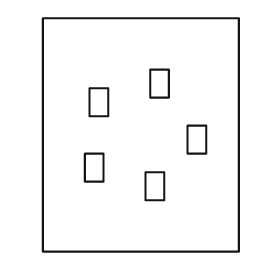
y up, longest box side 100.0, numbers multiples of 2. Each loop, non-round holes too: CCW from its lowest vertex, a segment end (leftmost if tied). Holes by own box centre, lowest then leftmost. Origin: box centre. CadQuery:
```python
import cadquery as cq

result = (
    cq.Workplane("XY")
    .moveTo(-42.0, -50.0)
    .lineTo(42.0, -50.0)
    .lineTo(42.0, 50.0)
    .lineTo(-42.0, 50.0)
    .close()
    .moveTo(2.0, -28.0)
    .lineTo(10.0, -28.0)
    .lineTo(10.0, -16.0)
    .lineTo(2.0, -16.0)
    .close()
    .moveTo(-24.0, -20.0)
    .lineTo(-16.0, -20.0)
    .lineTo(-16.0, -8.0)
    .lineTo(-24.0, -8.0)
    .close()
    .moveTo(20.0, -8.0)
    .lineTo(28.0, -8.0)
    .lineTo(28.0, 4.0)
    .lineTo(20.0, 4.0)
    .close()
    .moveTo(-22.0, 8.0)
    .lineTo(-14.0, 8.0)
    .lineTo(-14.0, 20.0)
    .lineTo(-22.0, 20.0)
    .close()
    .moveTo(4.0, 16.0)
    .lineTo(12.0, 16.0)
    .lineTo(12.0, 28.0)
    .lineTo(4.0, 28.0)
    .close()
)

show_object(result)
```